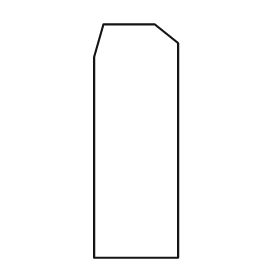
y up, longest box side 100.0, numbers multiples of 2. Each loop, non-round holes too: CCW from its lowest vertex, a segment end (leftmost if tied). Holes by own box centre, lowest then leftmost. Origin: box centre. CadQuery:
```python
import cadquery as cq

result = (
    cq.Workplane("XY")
    .moveTo(-18.0, -50.0)
    .lineTo(18.0, -50.0)
    .lineTo(18.0, 42.0)
    .lineTo(8.0, 50.0)
    .lineTo(-14.0, 50.0)
    .lineTo(-18.0, 36.0)
    .close()
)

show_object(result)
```